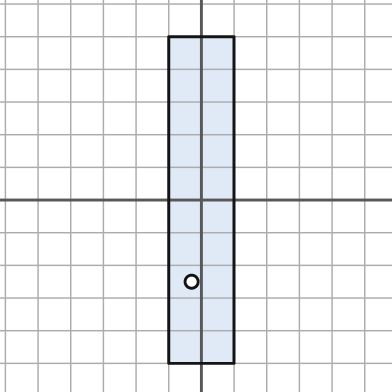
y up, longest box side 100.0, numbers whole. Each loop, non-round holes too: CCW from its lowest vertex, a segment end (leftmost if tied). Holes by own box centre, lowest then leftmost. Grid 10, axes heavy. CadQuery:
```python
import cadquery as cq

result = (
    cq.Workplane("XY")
    .moveTo(-10.0, -50.0)
    .lineTo(10.0, -50.0)
    .lineTo(10.0, 50.0)
    .lineTo(-10.0, 50.0)
    .close()
    .moveTo(-3.0, -25.0)
    .circle(2.0)
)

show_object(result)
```